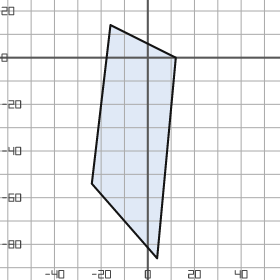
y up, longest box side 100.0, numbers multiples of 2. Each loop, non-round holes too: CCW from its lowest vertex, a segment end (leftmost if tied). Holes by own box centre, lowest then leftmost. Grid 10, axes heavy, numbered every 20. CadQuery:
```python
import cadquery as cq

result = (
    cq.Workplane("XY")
    .moveTo(4.0, -86.0)
    .lineTo(12.0, 0.0)
    .lineTo(-16.0, 14.0)
    .lineTo(-24.0, -54.0)
    .close()
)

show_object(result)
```